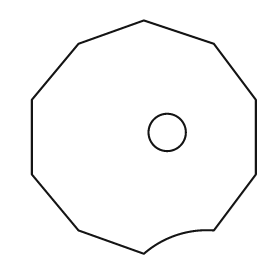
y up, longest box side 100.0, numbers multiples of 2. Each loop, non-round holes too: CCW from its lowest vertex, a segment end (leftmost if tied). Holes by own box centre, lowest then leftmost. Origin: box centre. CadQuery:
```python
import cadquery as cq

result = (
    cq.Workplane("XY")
    .moveTo(0.0, -50.0)
    .threePointArc((14.0, -42.0), (30.0, -40.0))
    .lineTo(48.0, -16.0)
    .lineTo(48.0, 16.0)
    .lineTo(30.0, 40.0)
    .lineTo(0.0, 50.0)
    .lineTo(-28.0, 40.0)
    .lineTo(-48.0, 16.0)
    .lineTo(-48.0, -16.0)
    .lineTo(-28.0, -40.0)
    .close()
    .moveTo(10.0, 2.0)
    .circle(8.0)
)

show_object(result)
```